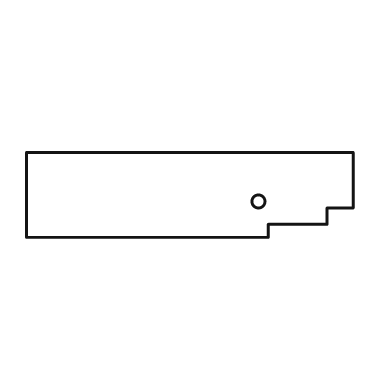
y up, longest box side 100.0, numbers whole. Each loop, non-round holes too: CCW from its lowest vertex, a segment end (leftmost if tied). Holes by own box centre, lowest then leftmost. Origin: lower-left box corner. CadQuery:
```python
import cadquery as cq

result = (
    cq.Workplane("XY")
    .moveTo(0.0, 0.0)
    .lineTo(74.0, 0.0)
    .lineTo(74.0, 4.0)
    .lineTo(92.0, 4.0)
    .lineTo(92.0, 9.0)
    .lineTo(100.0, 9.0)
    .lineTo(100.0, 26.0)
    .lineTo(0.0, 26.0)
    .close()
    .moveTo(71.0, 11.0)
    .circle(2.0)
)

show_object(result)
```